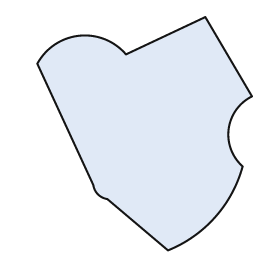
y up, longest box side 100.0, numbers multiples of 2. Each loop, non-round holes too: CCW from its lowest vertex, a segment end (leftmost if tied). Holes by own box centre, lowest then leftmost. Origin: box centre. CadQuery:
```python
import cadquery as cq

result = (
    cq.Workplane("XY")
    .moveTo(10.0, -50.0)
    .threePointArc((30.0, -36.0), (42.0, -14.0))
    .threePointArc((36.0, 2.0), (46.0, 16.0))
    .lineTo(26.0, 50.0)
    .lineTo(-8.0, 34.0)
    .threePointArc((-28.0, 42.0), (-46.0, 30.0))
    .lineTo(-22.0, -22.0)
    .threePointArc((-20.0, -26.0), (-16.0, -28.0))
    .close()
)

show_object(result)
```